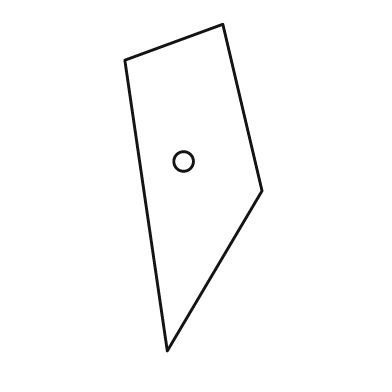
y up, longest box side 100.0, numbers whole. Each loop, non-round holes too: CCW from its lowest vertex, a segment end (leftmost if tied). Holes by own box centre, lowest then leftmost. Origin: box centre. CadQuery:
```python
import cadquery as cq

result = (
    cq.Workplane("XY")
    .moveTo(-8.0, -50.0)
    .lineTo(21.0, -1.0)
    .lineTo(9.0, 50.0)
    .lineTo(-21.0, 39.0)
    .close()
    .moveTo(-3.0, 8.0)
    .circle(3.0)
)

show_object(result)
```